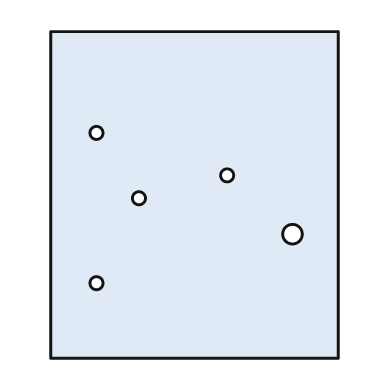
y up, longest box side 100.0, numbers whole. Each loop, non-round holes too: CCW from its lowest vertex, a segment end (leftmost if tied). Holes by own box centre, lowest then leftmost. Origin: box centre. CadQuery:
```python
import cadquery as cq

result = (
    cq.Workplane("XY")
    .moveTo(-44.0, -50.0)
    .lineTo(44.0, -50.0)
    .lineTo(44.0, 50.0)
    .lineTo(-44.0, 50.0)
    .close()
    .moveTo(-30.0, -27.0)
    .circle(2.0)
    .moveTo(30.0, -12.0)
    .circle(3.0)
    .moveTo(-17.0, -1.0)
    .circle(2.0)
    .moveTo(10.0, 6.0)
    .circle(2.0)
    .moveTo(-30.0, 19.0)
    .circle(2.0)
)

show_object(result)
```